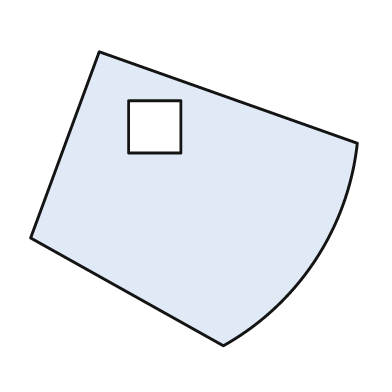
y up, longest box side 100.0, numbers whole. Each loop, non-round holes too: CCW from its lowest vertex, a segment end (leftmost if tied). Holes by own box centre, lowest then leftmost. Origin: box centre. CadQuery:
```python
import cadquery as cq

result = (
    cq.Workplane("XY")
    .moveTo(9.0, -45.0)
    .threePointArc((37.0, -19.0), (50.0, 17.0))
    .lineTo(-29.0, 45.0)
    .lineTo(-50.0, -12.0)
    .close()
    .moveTo(-20.0, 14.0)
    .lineTo(-4.0, 14.0)
    .lineTo(-4.0, 30.0)
    .lineTo(-20.0, 30.0)
    .close()
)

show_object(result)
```